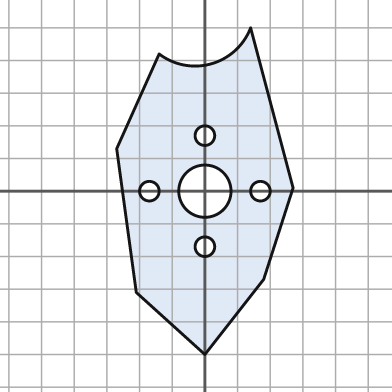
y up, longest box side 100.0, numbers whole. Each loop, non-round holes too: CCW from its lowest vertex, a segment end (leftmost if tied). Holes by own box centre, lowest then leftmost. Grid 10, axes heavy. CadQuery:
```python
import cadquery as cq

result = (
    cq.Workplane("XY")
    .moveTo(0.0, -50.0)
    .lineTo(18.0, -27.0)
    .lineTo(27.0, 1.0)
    .lineTo(14.0, 50.0)
    .threePointArc((2.0, 39.0), (-14.0, 42.0))
    .lineTo(-27.0, 13.0)
    .lineTo(-21.0, -31.0)
    .close()
    .moveTo(0.0, -17.0)
    .circle(3.0)
    .moveTo(-17.0, 0.0)
    .circle(3.0)
    .moveTo(0.0, 0.0)
    .circle(8.0)
    .moveTo(17.0, 0.0)
    .circle(3.0)
    .moveTo(0.0, 17.0)
    .circle(3.0)
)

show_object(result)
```